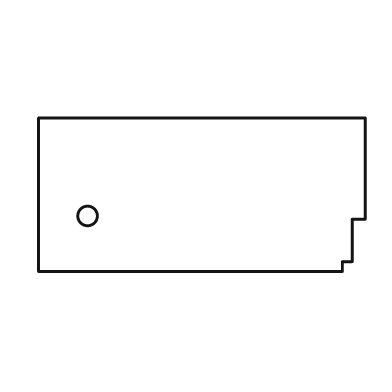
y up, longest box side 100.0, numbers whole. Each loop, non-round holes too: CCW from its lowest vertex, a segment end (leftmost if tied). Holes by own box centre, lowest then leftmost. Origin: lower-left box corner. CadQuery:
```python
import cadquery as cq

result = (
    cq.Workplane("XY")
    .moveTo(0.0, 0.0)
    .lineTo(93.0, 0.0)
    .lineTo(93.0, 3.0)
    .lineTo(96.0, 3.0)
    .lineTo(96.0, 16.0)
    .lineTo(100.0, 16.0)
    .lineTo(100.0, 47.0)
    .lineTo(0.0, 47.0)
    .close()
    .moveTo(15.0, 17.0)
    .circle(3.0)
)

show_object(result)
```